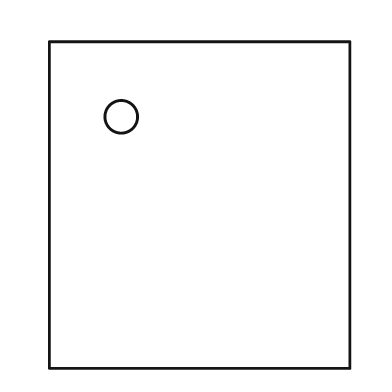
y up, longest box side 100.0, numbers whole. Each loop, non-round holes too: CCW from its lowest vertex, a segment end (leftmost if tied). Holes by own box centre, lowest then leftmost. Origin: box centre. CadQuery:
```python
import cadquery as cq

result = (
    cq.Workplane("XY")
    .moveTo(-46.0, -50.0)
    .lineTo(46.0, -50.0)
    .lineTo(46.0, 50.0)
    .lineTo(-46.0, 50.0)
    .close()
    .moveTo(-24.0, 27.0)
    .circle(5.0)
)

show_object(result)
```